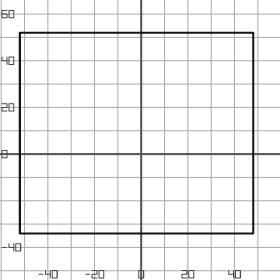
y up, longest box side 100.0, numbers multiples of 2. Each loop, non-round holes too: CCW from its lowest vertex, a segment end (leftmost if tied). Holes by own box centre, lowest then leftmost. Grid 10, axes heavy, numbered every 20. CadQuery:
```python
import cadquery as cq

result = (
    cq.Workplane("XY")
    .moveTo(-52.0, -34.0)
    .lineTo(48.0, -34.0)
    .lineTo(48.0, 52.0)
    .lineTo(-52.0, 52.0)
    .close()
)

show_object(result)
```